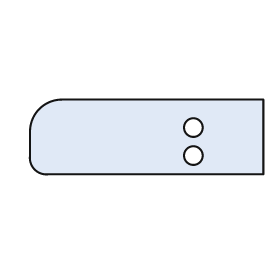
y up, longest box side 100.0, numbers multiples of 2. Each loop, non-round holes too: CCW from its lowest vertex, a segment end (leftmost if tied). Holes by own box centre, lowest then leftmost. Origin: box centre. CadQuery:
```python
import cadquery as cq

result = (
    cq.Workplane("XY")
    .moveTo(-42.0, -16.0)
    .lineTo(50.0, -16.0)
    .lineTo(50.0, 16.0)
    .lineTo(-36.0, 16.0)
    .threePointArc((-46.0, 12.0), (-50.0, 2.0))
    .lineTo(-50.0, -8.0)
    .threePointArc((-48.0, -14.0), (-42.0, -16.0))
    .close()
    .moveTo(20.0, -8.0)
    .circle(4.0)
    .moveTo(20.0, 4.0)
    .circle(4.0)
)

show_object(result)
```